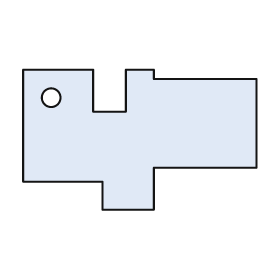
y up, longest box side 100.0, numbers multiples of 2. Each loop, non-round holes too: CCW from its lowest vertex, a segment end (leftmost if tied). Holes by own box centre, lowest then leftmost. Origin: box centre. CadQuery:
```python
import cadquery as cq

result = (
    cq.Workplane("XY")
    .moveTo(-16.0, -30.0)
    .lineTo(6.0, -30.0)
    .lineTo(6.0, -12.0)
    .lineTo(50.0, -12.0)
    .lineTo(50.0, 26.0)
    .lineTo(6.0, 26.0)
    .lineTo(6.0, 30.0)
    .lineTo(-6.0, 30.0)
    .lineTo(-6.0, 12.0)
    .lineTo(-20.0, 12.0)
    .lineTo(-20.0, 30.0)
    .lineTo(-50.0, 30.0)
    .lineTo(-50.0, -18.0)
    .lineTo(-16.0, -18.0)
    .close()
    .moveTo(-38.0, 18.0)
    .circle(4.0)
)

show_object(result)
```